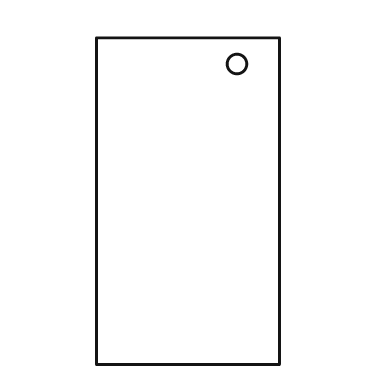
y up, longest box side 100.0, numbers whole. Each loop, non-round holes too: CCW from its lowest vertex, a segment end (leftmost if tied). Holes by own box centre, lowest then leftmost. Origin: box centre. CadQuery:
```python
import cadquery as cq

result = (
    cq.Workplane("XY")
    .moveTo(-28.0, -50.0)
    .lineTo(28.0, -50.0)
    .lineTo(28.0, 50.0)
    .lineTo(-28.0, 50.0)
    .close()
    .moveTo(15.0, 42.0)
    .circle(3.0)
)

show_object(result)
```